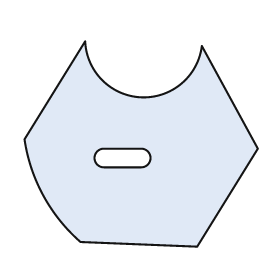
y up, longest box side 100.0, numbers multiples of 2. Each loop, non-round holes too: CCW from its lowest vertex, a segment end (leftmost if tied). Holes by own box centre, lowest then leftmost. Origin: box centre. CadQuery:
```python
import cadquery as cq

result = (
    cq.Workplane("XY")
    .moveTo(24.0, -44.0)
    .lineTo(50.0, -2.0)
    .lineTo(26.0, 42.0)
    .threePointArc((0.0, 20.0), (-24.0, 44.0))
    .lineTo(-50.0, 2.0)
    .threePointArc((-42.0, -22.0), (-26.0, -42.0))
    .close()
    .moveTo(-16.0, -10.0)
    .lineTo(0.0, -10.0)
    .threePointArc((4.0, -6.0), (0.0, -2.0))
    .lineTo(-16.0, -2.0)
    .threePointArc((-20.0, -6.0), (-16.0, -10.0))
    .close()
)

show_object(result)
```